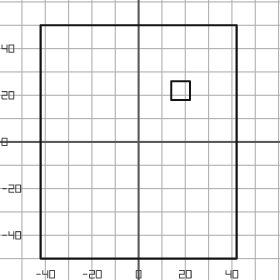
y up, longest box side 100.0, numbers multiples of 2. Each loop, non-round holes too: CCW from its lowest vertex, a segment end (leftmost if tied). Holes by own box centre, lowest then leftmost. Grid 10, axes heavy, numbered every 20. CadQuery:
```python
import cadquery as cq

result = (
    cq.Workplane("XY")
    .moveTo(-42.0, -50.0)
    .lineTo(42.0, -50.0)
    .lineTo(42.0, 50.0)
    .lineTo(-42.0, 50.0)
    .close()
    .moveTo(14.0, 18.0)
    .lineTo(22.0, 18.0)
    .lineTo(22.0, 26.0)
    .lineTo(14.0, 26.0)
    .close()
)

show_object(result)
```